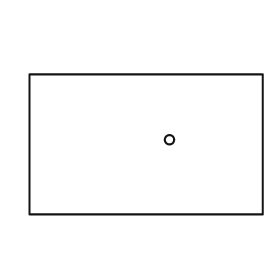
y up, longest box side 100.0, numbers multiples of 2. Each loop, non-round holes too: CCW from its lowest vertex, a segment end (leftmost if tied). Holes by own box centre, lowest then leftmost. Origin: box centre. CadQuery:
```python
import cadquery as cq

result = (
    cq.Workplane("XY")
    .moveTo(-50.0, -30.0)
    .lineTo(50.0, -30.0)
    .lineTo(50.0, 30.0)
    .lineTo(-50.0, 30.0)
    .close()
    .moveTo(10.0, 2.0)
    .circle(2.0)
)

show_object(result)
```